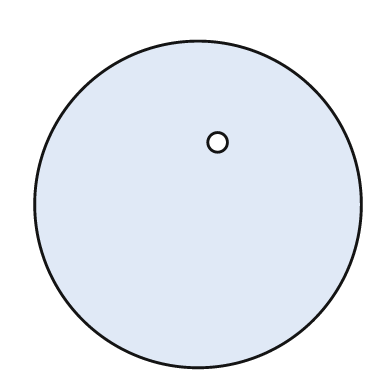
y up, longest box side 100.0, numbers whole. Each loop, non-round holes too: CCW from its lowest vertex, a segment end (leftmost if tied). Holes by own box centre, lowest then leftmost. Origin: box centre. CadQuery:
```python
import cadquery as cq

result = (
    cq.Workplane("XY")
    .moveTo(0.0, 0.0)
    .circle(50.0)
    .moveTo(6.0, 19.0)
    .circle(3.0)
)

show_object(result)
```